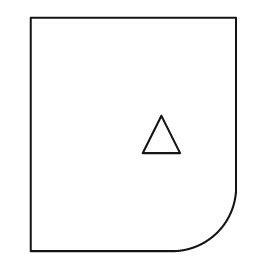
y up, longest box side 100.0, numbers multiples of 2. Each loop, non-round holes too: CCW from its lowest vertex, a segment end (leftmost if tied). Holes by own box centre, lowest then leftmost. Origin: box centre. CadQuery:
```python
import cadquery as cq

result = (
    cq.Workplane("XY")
    .moveTo(-44.0, -50.0)
    .lineTo(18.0, -50.0)
    .threePointArc((36.0, -42.0), (44.0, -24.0))
    .lineTo(44.0, 50.0)
    .lineTo(-44.0, 50.0)
    .close()
    .moveTo(4.0, -8.0)
    .lineTo(20.0, -8.0)
    .lineTo(12.0, 8.0)
    .close()
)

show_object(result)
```